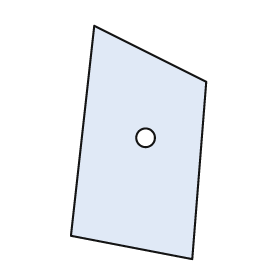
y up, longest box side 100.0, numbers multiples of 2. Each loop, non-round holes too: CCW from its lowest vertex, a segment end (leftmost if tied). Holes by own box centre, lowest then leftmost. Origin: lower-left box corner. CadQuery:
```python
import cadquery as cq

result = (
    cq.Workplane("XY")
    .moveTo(52.0, 0.0)
    .lineTo(58.0, 76.0)
    .lineTo(10.0, 100.0)
    .lineTo(0.0, 10.0)
    .close()
    .moveTo(32.0, 52.0)
    .circle(4.0)
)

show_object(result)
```